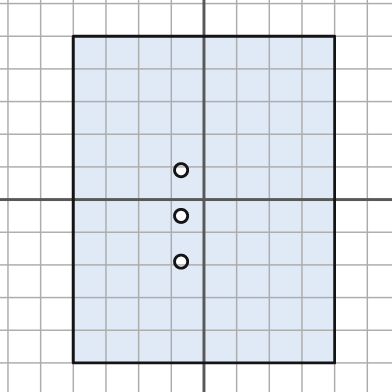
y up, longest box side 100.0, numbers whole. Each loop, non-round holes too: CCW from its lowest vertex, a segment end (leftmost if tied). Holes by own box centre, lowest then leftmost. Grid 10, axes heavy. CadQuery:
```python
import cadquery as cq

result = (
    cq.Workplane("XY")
    .moveTo(-40.0, -50.0)
    .lineTo(40.0, -50.0)
    .lineTo(40.0, 50.0)
    .lineTo(-40.0, 50.0)
    .close()
    .moveTo(-7.0, -19.0)
    .circle(2.0)
    .moveTo(-7.0, -5.0)
    .circle(2.0)
    .moveTo(-7.0, 9.0)
    .circle(2.0)
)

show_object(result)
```